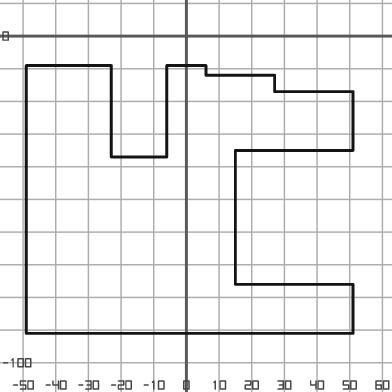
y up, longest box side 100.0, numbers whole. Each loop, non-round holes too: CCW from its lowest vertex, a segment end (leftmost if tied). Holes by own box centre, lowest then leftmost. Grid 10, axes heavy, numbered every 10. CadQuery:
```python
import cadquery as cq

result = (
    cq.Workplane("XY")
    .moveTo(-49.0, -91.0)
    .lineTo(51.0, -91.0)
    .lineTo(51.0, -76.0)
    .lineTo(15.0, -76.0)
    .lineTo(15.0, -35.0)
    .lineTo(51.0, -35.0)
    .lineTo(51.0, -17.0)
    .lineTo(27.0, -17.0)
    .lineTo(27.0, -12.0)
    .lineTo(6.0, -12.0)
    .lineTo(6.0, -9.0)
    .lineTo(-6.0, -9.0)
    .lineTo(-6.0, -37.0)
    .lineTo(-23.0, -37.0)
    .lineTo(-23.0, -9.0)
    .lineTo(-49.0, -9.0)
    .close()
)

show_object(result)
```